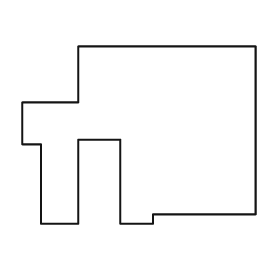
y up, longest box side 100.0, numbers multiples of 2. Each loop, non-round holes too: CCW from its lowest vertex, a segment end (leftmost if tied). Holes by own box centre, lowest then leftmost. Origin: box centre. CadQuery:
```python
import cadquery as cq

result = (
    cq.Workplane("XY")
    .moveTo(-42.0, -38.0)
    .lineTo(-26.0, -38.0)
    .lineTo(-26.0, -2.0)
    .lineTo(-8.0, -2.0)
    .lineTo(-8.0, -38.0)
    .lineTo(6.0, -38.0)
    .lineTo(6.0, -34.0)
    .lineTo(50.0, -34.0)
    .lineTo(50.0, 38.0)
    .lineTo(-26.0, 38.0)
    .lineTo(-26.0, 14.0)
    .lineTo(-50.0, 14.0)
    .lineTo(-50.0, -4.0)
    .lineTo(-42.0, -4.0)
    .close()
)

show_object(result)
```